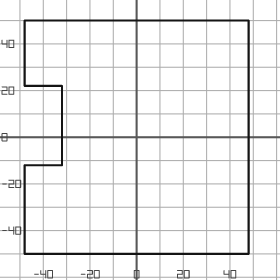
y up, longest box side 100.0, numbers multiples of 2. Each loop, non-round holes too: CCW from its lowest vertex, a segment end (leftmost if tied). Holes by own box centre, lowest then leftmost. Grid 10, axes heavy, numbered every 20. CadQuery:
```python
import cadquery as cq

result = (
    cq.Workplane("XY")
    .moveTo(-48.0, -50.0)
    .lineTo(48.0, -50.0)
    .lineTo(48.0, 50.0)
    .lineTo(-48.0, 50.0)
    .lineTo(-48.0, 22.0)
    .lineTo(-32.0, 22.0)
    .lineTo(-32.0, -12.0)
    .lineTo(-48.0, -12.0)
    .close()
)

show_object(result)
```